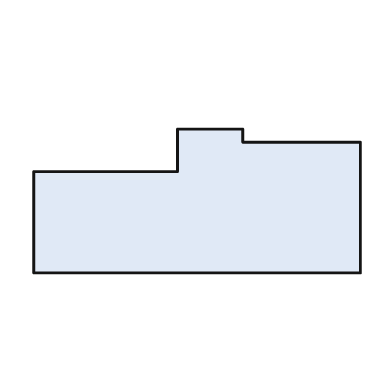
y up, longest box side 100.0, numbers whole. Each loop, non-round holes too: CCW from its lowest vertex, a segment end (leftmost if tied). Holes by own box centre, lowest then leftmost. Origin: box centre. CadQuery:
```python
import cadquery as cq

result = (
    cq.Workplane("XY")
    .moveTo(-50.0, -22.0)
    .lineTo(50.0, -22.0)
    .lineTo(50.0, 18.0)
    .lineTo(14.0, 18.0)
    .lineTo(14.0, 22.0)
    .lineTo(-6.0, 22.0)
    .lineTo(-6.0, 9.0)
    .lineTo(-50.0, 9.0)
    .close()
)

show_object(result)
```